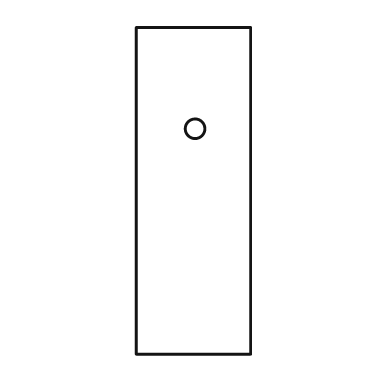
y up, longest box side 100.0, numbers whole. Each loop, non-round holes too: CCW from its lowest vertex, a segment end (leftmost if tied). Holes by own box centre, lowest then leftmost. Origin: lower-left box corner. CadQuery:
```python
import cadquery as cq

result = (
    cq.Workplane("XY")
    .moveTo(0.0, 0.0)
    .lineTo(35.0, 0.0)
    .lineTo(35.0, 100.0)
    .lineTo(0.0, 100.0)
    .close()
    .moveTo(18.0, 69.0)
    .circle(3.0)
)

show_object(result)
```